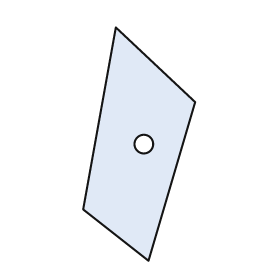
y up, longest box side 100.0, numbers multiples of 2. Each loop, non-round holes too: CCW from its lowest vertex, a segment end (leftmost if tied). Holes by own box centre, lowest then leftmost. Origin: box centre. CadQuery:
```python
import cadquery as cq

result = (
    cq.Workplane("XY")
    .moveTo(4.0, -50.0)
    .lineTo(24.0, 18.0)
    .lineTo(-10.0, 50.0)
    .lineTo(-24.0, -28.0)
    .close()
    .moveTo(2.0, 0.0)
    .circle(4.0)
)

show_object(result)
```